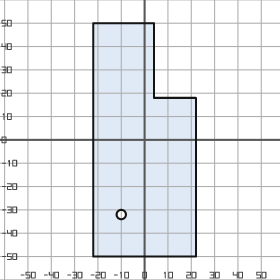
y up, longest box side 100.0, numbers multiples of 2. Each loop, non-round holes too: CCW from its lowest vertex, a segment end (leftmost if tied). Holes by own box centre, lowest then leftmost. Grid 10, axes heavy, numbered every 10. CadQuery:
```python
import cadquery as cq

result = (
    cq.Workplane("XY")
    .moveTo(-22.0, -50.0)
    .lineTo(22.0, -50.0)
    .lineTo(22.0, 18.0)
    .lineTo(4.0, 18.0)
    .lineTo(4.0, 50.0)
    .lineTo(-22.0, 50.0)
    .close()
    .moveTo(-10.0, -32.0)
    .circle(2.0)
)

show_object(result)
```